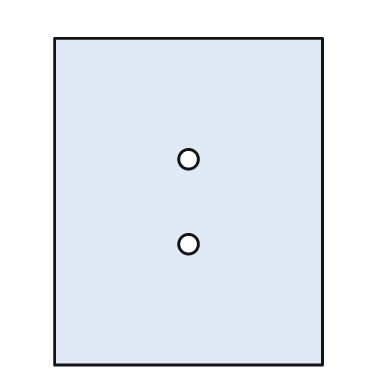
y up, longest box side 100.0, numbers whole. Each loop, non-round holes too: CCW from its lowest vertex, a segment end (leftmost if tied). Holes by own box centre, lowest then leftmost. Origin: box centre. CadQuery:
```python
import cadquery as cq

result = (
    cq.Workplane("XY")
    .moveTo(-41.0, -50.0)
    .lineTo(41.0, -50.0)
    .lineTo(41.0, 50.0)
    .lineTo(-41.0, 50.0)
    .close()
    .moveTo(0.0, -13.0)
    .circle(3.0)
    .moveTo(0.0, 13.0)
    .circle(3.0)
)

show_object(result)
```